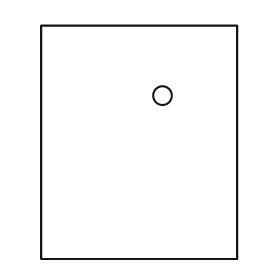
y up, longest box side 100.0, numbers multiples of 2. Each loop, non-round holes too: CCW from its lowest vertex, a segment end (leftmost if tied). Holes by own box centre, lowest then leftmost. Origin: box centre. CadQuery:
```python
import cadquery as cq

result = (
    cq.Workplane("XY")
    .moveTo(-42.0, -50.0)
    .lineTo(42.0, -50.0)
    .lineTo(42.0, 50.0)
    .lineTo(-42.0, 50.0)
    .close()
    .moveTo(10.0, 20.0)
    .circle(4.0)
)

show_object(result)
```